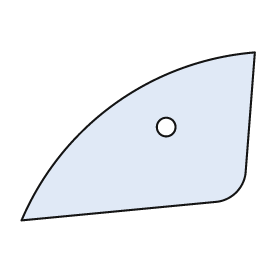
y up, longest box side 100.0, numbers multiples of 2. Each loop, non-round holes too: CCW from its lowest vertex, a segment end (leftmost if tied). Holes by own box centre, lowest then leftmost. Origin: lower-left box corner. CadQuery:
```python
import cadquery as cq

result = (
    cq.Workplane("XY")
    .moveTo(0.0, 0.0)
    .lineTo(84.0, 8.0)
    .threePointArc((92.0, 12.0), (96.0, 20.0))
    .lineTo(100.0, 72.0)
    .threePointArc((40.0, 50.0), (0.0, 0.0))
    .close()
    .moveTo(62.0, 40.0)
    .circle(4.0)
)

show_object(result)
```